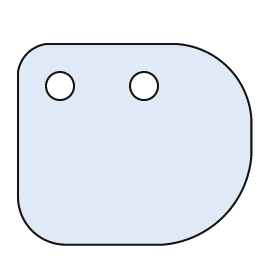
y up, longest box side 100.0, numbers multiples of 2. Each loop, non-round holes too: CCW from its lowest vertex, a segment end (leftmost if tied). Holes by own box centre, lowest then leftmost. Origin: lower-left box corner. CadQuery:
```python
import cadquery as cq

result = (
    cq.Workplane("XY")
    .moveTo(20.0, 0.0)
    .lineTo(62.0, 0.0)
    .threePointArc((88.0, 12.0), (100.0, 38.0))
    .lineTo(100.0, 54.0)
    .threePointArc((90.0, 76.0), (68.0, 86.0))
    .lineTo(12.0, 86.0)
    .threePointArc((4.0, 82.0), (0.0, 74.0))
    .lineTo(0.0, 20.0)
    .threePointArc((6.0, 6.0), (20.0, 0.0))
    .close()
    .moveTo(18.0, 68.0)
    .circle(6.0)
    .moveTo(54.0, 68.0)
    .circle(6.0)
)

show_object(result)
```